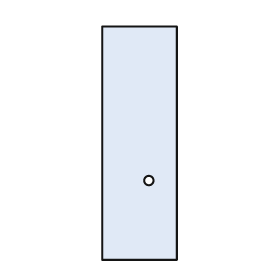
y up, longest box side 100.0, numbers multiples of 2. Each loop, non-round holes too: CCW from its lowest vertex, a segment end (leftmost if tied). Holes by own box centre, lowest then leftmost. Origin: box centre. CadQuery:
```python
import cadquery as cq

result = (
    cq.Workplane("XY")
    .moveTo(-16.0, -50.0)
    .lineTo(16.0, -50.0)
    .lineTo(16.0, 50.0)
    .lineTo(-16.0, 50.0)
    .close()
    .moveTo(4.0, -16.0)
    .circle(2.0)
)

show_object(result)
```